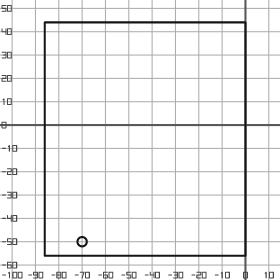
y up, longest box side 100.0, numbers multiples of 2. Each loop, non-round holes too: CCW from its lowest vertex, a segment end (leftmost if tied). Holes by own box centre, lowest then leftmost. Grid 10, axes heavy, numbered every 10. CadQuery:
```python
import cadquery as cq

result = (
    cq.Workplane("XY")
    .moveTo(-86.0, -56.0)
    .lineTo(0.0, -56.0)
    .lineTo(0.0, 44.0)
    .lineTo(-86.0, 44.0)
    .close()
    .moveTo(-70.0, -50.0)
    .circle(2.0)
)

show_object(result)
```